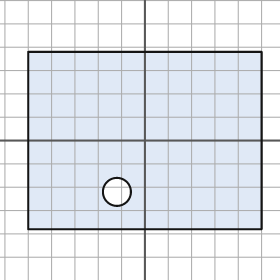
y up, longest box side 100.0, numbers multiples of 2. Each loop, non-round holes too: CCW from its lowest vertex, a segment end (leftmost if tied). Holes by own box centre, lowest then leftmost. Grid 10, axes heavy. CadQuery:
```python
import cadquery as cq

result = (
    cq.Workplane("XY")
    .moveTo(-50.0, -38.0)
    .lineTo(50.0, -38.0)
    .lineTo(50.0, 38.0)
    .lineTo(-50.0, 38.0)
    .close()
    .moveTo(-12.0, -22.0)
    .circle(6.0)
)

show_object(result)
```